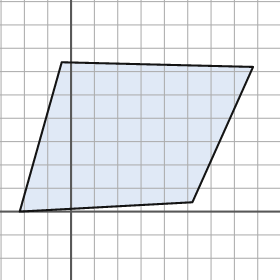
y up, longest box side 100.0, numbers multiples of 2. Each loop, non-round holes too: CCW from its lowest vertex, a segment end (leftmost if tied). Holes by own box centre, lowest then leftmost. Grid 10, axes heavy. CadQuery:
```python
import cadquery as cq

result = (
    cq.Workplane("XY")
    .moveTo(-22.0, 0.0)
    .lineTo(52.0, 4.0)
    .lineTo(78.0, 62.0)
    .lineTo(-4.0, 64.0)
    .close()
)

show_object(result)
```